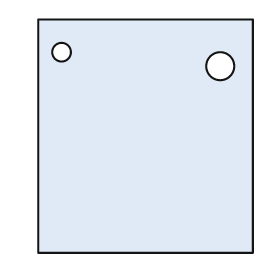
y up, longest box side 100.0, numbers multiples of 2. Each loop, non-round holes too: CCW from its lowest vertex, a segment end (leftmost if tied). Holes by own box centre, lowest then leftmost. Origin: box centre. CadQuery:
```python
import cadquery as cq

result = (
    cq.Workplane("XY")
    .moveTo(-46.0, -50.0)
    .lineTo(46.0, -50.0)
    .lineTo(46.0, 50.0)
    .lineTo(-46.0, 50.0)
    .close()
    .moveTo(32.0, 30.0)
    .circle(6.0)
    .moveTo(-36.0, 36.0)
    .circle(4.0)
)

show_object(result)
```